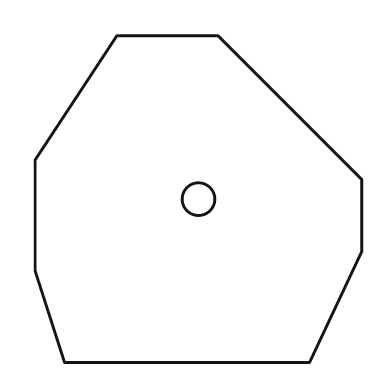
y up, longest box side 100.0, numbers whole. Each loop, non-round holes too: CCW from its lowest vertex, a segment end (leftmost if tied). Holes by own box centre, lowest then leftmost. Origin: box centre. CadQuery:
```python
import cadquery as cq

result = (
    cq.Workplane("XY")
    .moveTo(-41.0, -50.0)
    .lineTo(34.0, -50.0)
    .lineTo(50.0, -16.0)
    .lineTo(50.0, 6.0)
    .lineTo(6.0, 50.0)
    .lineTo(-25.0, 50.0)
    .lineTo(-50.0, 12.0)
    .lineTo(-50.0, -22.0)
    .close()
    .moveTo(0.0, 0.0)
    .circle(5.0)
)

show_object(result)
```